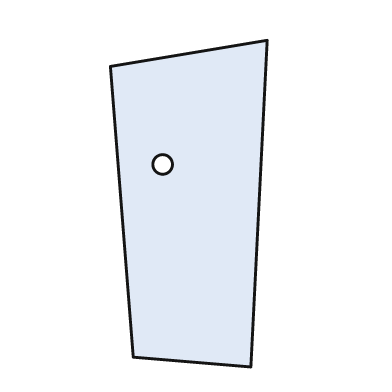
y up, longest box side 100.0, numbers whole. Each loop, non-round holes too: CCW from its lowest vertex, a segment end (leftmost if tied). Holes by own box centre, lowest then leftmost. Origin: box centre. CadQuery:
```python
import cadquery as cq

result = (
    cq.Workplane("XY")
    .moveTo(19.0, -50.0)
    .lineTo(24.0, 50.0)
    .lineTo(-24.0, 42.0)
    .lineTo(-17.0, -47.0)
    .close()
    .moveTo(-8.0, 12.0)
    .circle(3.0)
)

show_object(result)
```